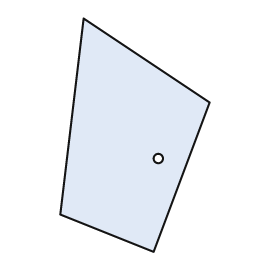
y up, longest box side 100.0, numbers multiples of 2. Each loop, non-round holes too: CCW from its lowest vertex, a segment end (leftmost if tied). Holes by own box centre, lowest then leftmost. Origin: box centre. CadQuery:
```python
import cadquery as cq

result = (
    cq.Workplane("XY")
    .moveTo(8.0, -50.0)
    .lineTo(32.0, 14.0)
    .lineTo(-22.0, 50.0)
    .lineTo(-32.0, -34.0)
    .close()
    .moveTo(10.0, -10.0)
    .circle(2.0)
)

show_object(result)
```